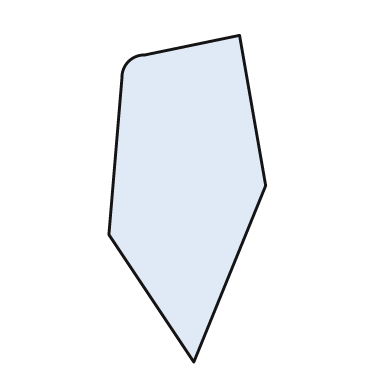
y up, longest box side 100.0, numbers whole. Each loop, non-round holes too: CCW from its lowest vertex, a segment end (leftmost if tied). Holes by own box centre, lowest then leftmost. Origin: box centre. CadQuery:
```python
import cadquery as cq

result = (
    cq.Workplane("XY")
    .moveTo(2.0, -50.0)
    .lineTo(24.0, 4.0)
    .lineTo(16.0, 50.0)
    .lineTo(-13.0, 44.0)
    .threePointArc((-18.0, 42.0), (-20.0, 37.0))
    .lineTo(-24.0, -11.0)
    .close()
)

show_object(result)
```